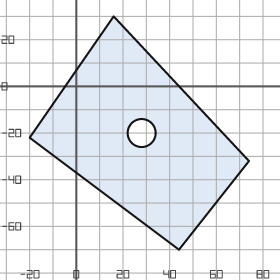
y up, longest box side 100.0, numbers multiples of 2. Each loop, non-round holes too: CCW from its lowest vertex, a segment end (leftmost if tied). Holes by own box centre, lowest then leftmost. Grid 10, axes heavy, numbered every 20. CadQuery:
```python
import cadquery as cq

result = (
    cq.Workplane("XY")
    .moveTo(44.0, -70.0)
    .lineTo(74.0, -32.0)
    .lineTo(16.0, 30.0)
    .lineTo(-20.0, -22.0)
    .close()
    .moveTo(28.0, -20.0)
    .circle(6.0)
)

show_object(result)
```